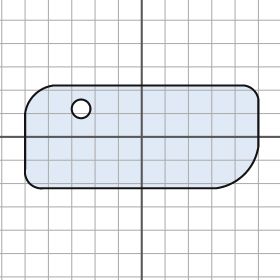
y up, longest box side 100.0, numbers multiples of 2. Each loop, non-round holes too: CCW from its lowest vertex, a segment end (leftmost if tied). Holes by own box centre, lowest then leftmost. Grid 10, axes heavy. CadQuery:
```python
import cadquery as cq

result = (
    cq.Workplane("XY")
    .moveTo(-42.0, -22.0)
    .lineTo(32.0, -22.0)
    .threePointArc((44.0, -16.0), (50.0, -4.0))
    .lineTo(50.0, 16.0)
    .threePointArc((48.0, 20.0), (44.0, 22.0))
    .lineTo(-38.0, 22.0)
    .threePointArc((-46.0, 18.0), (-50.0, 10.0))
    .lineTo(-50.0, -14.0)
    .threePointArc((-48.0, -20.0), (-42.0, -22.0))
    .close()
    .moveTo(-26.0, 12.0)
    .circle(4.0)
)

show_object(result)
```